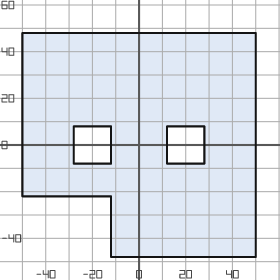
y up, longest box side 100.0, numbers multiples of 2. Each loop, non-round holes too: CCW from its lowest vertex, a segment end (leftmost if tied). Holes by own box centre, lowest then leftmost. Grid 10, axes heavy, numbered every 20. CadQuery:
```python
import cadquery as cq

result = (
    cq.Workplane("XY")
    .moveTo(-12.0, -48.0)
    .lineTo(50.0, -48.0)
    .lineTo(50.0, 48.0)
    .lineTo(-50.0, 48.0)
    .lineTo(-50.0, -22.0)
    .lineTo(-12.0, -22.0)
    .close()
    .moveTo(-28.0, -8.0)
    .lineTo(-12.0, -8.0)
    .lineTo(-12.0, 8.0)
    .lineTo(-28.0, 8.0)
    .close()
    .moveTo(12.0, -8.0)
    .lineTo(28.0, -8.0)
    .lineTo(28.0, 8.0)
    .lineTo(12.0, 8.0)
    .close()
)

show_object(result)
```